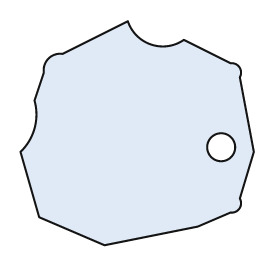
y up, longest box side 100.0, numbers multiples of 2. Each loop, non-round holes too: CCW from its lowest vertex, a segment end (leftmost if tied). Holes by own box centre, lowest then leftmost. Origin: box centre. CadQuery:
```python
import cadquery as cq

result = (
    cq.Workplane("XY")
    .moveTo(-14.0, -48.0)
    .lineTo(26.0, -40.0)
    .lineTo(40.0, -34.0)
    .threePointArc((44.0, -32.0), (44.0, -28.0))
    .lineTo(50.0, -8.0)
    .lineTo(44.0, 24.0)
    .threePointArc((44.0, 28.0), (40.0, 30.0))
    .lineTo(20.0, 40.0)
    .threePointArc((6.0, 38.0), (-4.0, 48.0))
    .lineTo(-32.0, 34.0)
    .threePointArc((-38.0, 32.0), (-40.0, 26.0))
    .lineTo(-44.0, 14.0)
    .threePointArc((-44.0, 2.0), (-50.0, -8.0))
    .lineTo(-42.0, -36.0)
    .close()
    .moveTo(36.0, -6.0)
    .circle(6.0)
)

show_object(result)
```